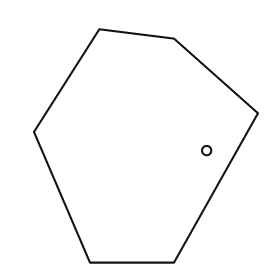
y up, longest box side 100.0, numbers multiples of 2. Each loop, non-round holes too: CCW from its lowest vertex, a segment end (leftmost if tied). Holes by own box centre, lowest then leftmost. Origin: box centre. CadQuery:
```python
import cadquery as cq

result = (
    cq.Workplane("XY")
    .moveTo(-24.0, -50.0)
    .lineTo(12.0, -50.0)
    .lineTo(48.0, 14.0)
    .lineTo(12.0, 46.0)
    .lineTo(-20.0, 50.0)
    .lineTo(-48.0, 6.0)
    .close()
    .moveTo(26.0, -2.0)
    .circle(2.0)
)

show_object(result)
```